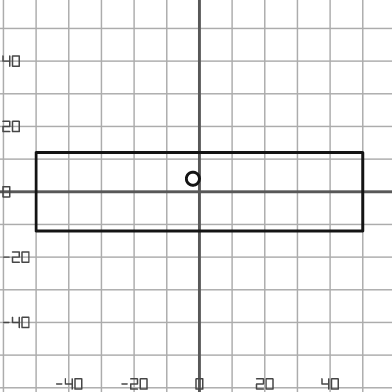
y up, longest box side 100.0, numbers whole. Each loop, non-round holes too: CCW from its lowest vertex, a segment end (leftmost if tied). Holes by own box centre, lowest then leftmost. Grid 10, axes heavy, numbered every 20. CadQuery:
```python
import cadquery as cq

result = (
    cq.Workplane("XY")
    .moveTo(-50.0, -12.0)
    .lineTo(50.0, -12.0)
    .lineTo(50.0, 12.0)
    .lineTo(-50.0, 12.0)
    .close()
    .moveTo(-2.0, 4.0)
    .circle(2.0)
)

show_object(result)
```